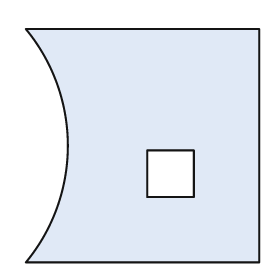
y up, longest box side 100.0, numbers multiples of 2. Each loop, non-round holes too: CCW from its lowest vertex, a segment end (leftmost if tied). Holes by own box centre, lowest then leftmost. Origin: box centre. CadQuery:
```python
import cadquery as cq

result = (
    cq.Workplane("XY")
    .moveTo(-50.0, -50.0)
    .lineTo(50.0, -50.0)
    .lineTo(50.0, 50.0)
    .lineTo(-50.0, 50.0)
    .threePointArc((-32.0, 0.0), (-50.0, -50.0))
    .close()
    .moveTo(2.0, -22.0)
    .lineTo(22.0, -22.0)
    .lineTo(22.0, -2.0)
    .lineTo(2.0, -2.0)
    .close()
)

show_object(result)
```